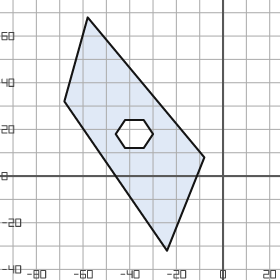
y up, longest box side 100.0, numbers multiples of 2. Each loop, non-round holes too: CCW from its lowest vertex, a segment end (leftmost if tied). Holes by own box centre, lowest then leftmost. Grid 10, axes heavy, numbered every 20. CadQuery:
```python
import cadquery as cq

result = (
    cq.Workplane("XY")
    .moveTo(-24.0, -32.0)
    .lineTo(-8.0, 8.0)
    .lineTo(-58.0, 68.0)
    .lineTo(-68.0, 32.0)
    .close()
    .moveTo(-42.0, 12.0)
    .lineTo(-34.0, 12.0)
    .lineTo(-30.0, 18.0)
    .lineTo(-34.0, 24.0)
    .lineTo(-42.0, 24.0)
    .lineTo(-46.0, 18.0)
    .close()
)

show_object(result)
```